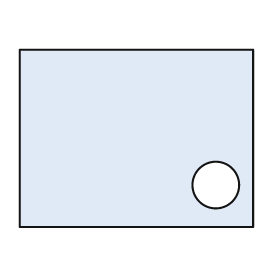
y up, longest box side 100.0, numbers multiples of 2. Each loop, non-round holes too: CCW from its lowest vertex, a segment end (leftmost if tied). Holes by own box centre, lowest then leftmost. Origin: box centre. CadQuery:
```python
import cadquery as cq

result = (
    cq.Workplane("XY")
    .moveTo(-50.0, -38.0)
    .lineTo(50.0, -38.0)
    .lineTo(50.0, 38.0)
    .lineTo(-50.0, 38.0)
    .close()
    .moveTo(34.0, -20.0)
    .circle(10.0)
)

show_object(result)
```